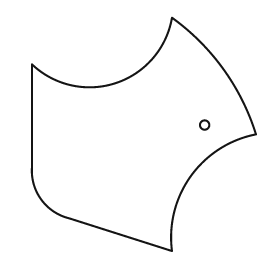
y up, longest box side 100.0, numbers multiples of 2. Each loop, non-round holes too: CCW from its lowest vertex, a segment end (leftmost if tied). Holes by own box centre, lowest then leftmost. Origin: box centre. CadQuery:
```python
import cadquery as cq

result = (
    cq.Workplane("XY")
    .moveTo(12.0, -50.0)
    .threePointArc((20.0, -18.0), (48.0, 0.0))
    .threePointArc((34.0, 28.0), (12.0, 50.0))
    .threePointArc((-12.0, 22.0), (-48.0, 30.0))
    .lineTo(-48.0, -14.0)
    .threePointArc((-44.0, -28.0), (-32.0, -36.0))
    .close()
    .moveTo(26.0, 4.0)
    .circle(2.0)
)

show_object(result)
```